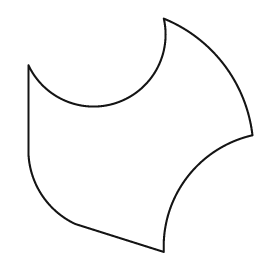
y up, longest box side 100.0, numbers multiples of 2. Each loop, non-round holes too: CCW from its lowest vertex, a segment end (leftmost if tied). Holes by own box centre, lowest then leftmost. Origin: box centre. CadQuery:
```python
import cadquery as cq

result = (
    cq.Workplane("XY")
    .moveTo(10.0, -50.0)
    .threePointArc((20.0, -18.0), (48.0, 0.0))
    .threePointArc((36.0, 30.0), (10.0, 50.0))
    .threePointArc((-10.0, 14.0), (-48.0, 30.0))
    .lineTo(-48.0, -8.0)
    .threePointArc((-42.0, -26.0), (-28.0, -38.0))
    .close()
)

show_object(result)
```